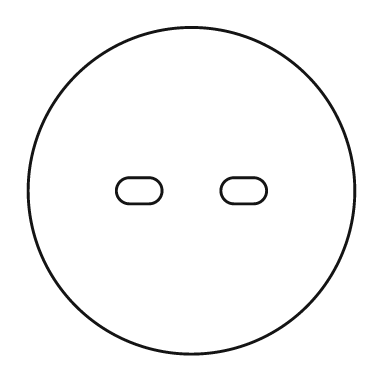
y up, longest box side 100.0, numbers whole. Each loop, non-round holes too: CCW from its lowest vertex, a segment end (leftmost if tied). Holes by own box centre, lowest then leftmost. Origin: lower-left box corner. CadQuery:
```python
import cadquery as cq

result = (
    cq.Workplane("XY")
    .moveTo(50.0, 50.0)
    .circle(50.0)
    .moveTo(31.0, 46.0)
    .lineTo(37.0, 46.0)
    .threePointArc((41.0, 50.0), (37.0, 54.0))
    .lineTo(31.0, 54.0)
    .threePointArc((27.0, 50.0), (31.0, 46.0))
    .close()
    .moveTo(63.0, 46.0)
    .lineTo(69.0, 46.0)
    .threePointArc((73.0, 50.0), (69.0, 54.0))
    .lineTo(63.0, 54.0)
    .threePointArc((59.0, 50.0), (63.0, 46.0))
    .close()
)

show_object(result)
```